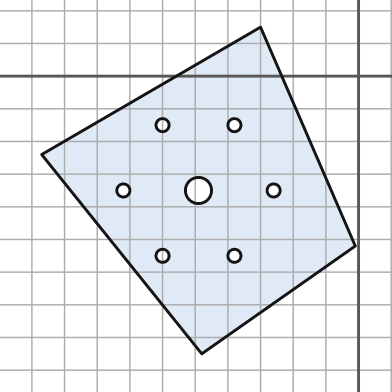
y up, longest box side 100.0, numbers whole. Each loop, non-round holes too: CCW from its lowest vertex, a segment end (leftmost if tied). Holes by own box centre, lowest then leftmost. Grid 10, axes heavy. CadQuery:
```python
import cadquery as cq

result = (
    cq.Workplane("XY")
    .moveTo(-48.0, -85.0)
    .lineTo(-1.0, -52.0)
    .lineTo(-30.0, 15.0)
    .lineTo(-97.0, -24.0)
    .close()
    .moveTo(-60.0, -55.0)
    .circle(2.0)
    .moveTo(-38.0, -55.0)
    .circle(2.0)
    .moveTo(-72.0, -35.0)
    .circle(2.0)
    .moveTo(-49.0, -35.0)
    .circle(4.0)
    .moveTo(-26.0, -35.0)
    .circle(2.0)
    .moveTo(-60.0, -15.0)
    .circle(2.0)
    .moveTo(-38.0, -15.0)
    .circle(2.0)
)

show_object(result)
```